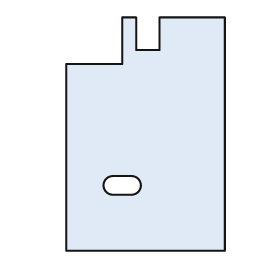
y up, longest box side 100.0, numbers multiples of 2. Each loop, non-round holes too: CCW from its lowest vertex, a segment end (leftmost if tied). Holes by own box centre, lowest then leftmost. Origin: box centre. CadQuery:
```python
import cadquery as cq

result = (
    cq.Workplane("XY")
    .moveTo(-34.0, -50.0)
    .lineTo(34.0, -50.0)
    .lineTo(34.0, 50.0)
    .lineTo(6.0, 50.0)
    .lineTo(6.0, 36.0)
    .lineTo(-4.0, 36.0)
    .lineTo(-4.0, 50.0)
    .lineTo(-10.0, 50.0)
    .lineTo(-10.0, 30.0)
    .lineTo(-34.0, 30.0)
    .close()
    .moveTo(-14.0, -26.0)
    .lineTo(-6.0, -26.0)
    .threePointArc((-2.0, -22.0), (-6.0, -18.0))
    .lineTo(-14.0, -18.0)
    .threePointArc((-18.0, -22.0), (-14.0, -26.0))
    .close()
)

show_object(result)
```